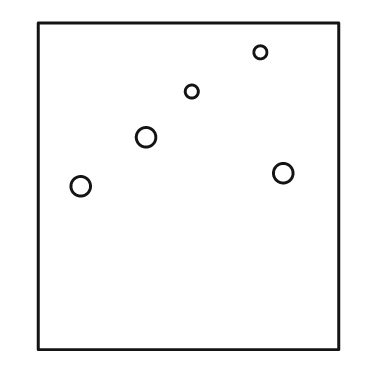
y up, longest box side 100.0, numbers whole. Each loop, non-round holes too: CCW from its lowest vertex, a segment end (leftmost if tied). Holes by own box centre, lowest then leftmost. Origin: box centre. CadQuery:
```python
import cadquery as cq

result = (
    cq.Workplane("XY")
    .moveTo(-46.0, -50.0)
    .lineTo(46.0, -50.0)
    .lineTo(46.0, 50.0)
    .lineTo(-46.0, 50.0)
    .close()
    .moveTo(-33.0, 0.0)
    .circle(3.0)
    .moveTo(29.0, 4.0)
    .circle(3.0)
    .moveTo(-13.0, 15.0)
    .circle(3.0)
    .moveTo(1.0, 29.0)
    .circle(2.0)
    .moveTo(22.0, 41.0)
    .circle(2.0)
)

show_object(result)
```